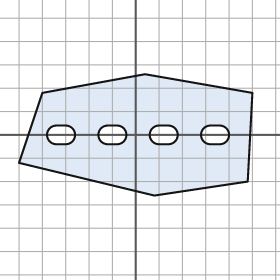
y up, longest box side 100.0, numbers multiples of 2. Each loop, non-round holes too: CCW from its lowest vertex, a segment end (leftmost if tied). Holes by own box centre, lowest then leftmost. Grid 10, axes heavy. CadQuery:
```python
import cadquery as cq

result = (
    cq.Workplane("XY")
    .moveTo(8.0, -26.0)
    .lineTo(48.0, -20.0)
    .lineTo(50.0, 18.0)
    .lineTo(4.0, 26.0)
    .lineTo(-40.0, 18.0)
    .lineTo(-50.0, -12.0)
    .close()
    .moveTo(-34.0, -4.0)
    .lineTo(-30.0, -4.0)
    .threePointArc((-26.0, 0.0), (-30.0, 4.0))
    .lineTo(-34.0, 4.0)
    .threePointArc((-38.0, 0.0), (-34.0, -4.0))
    .close()
    .moveTo(-12.0, -4.0)
    .lineTo(-8.0, -4.0)
    .threePointArc((-4.0, 0.0), (-8.0, 4.0))
    .lineTo(-12.0, 4.0)
    .threePointArc((-16.0, 0.0), (-12.0, -4.0))
    .close()
    .moveTo(10.0, -4.0)
    .lineTo(14.0, -4.0)
    .threePointArc((18.0, 0.0), (14.0, 4.0))
    .lineTo(10.0, 4.0)
    .threePointArc((6.0, 0.0), (10.0, -4.0))
    .close()
    .moveTo(32.0, -4.0)
    .lineTo(36.0, -4.0)
    .threePointArc((40.0, 0.0), (36.0, 4.0))
    .lineTo(32.0, 4.0)
    .threePointArc((28.0, 0.0), (32.0, -4.0))
    .close()
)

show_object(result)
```